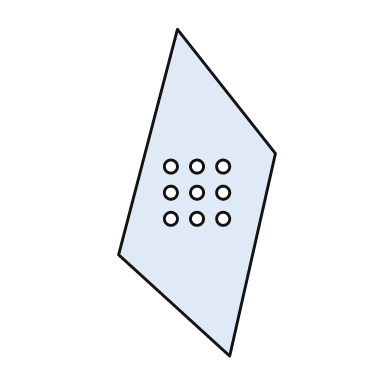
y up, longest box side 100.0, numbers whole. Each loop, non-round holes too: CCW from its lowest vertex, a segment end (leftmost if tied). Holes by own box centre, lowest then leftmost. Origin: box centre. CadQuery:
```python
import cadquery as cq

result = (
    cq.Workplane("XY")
    .moveTo(10.0, -50.0)
    .lineTo(24.0, 12.0)
    .lineTo(-6.0, 50.0)
    .lineTo(-24.0, -19.0)
    .close()
    .moveTo(-8.0, -8.0)
    .circle(2.0)
    .moveTo(0.0, -8.0)
    .circle(2.0)
    .moveTo(8.0, -8.0)
    .circle(2.0)
    .moveTo(-8.0, 0.0)
    .circle(2.0)
    .moveTo(0.0, 0.0)
    .circle(2.0)
    .moveTo(8.0, 0.0)
    .circle(2.0)
    .moveTo(-8.0, 8.0)
    .circle(2.0)
    .moveTo(0.0, 8.0)
    .circle(2.0)
    .moveTo(8.0, 8.0)
    .circle(2.0)
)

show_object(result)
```